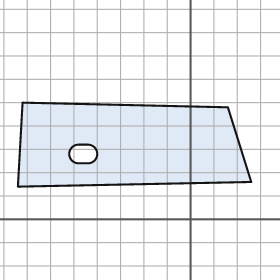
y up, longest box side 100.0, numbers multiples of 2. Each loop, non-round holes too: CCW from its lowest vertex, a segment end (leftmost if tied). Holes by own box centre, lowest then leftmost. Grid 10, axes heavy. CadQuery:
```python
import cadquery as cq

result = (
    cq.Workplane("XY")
    .moveTo(-74.0, 14.0)
    .lineTo(26.0, 16.0)
    .lineTo(16.0, 48.0)
    .lineTo(-72.0, 50.0)
    .close()
    .moveTo(-48.0, 24.0)
    .lineTo(-44.0, 24.0)
    .threePointArc((-40.0, 28.0), (-44.0, 32.0))
    .lineTo(-48.0, 32.0)
    .threePointArc((-52.0, 28.0), (-48.0, 24.0))
    .close()
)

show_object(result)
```